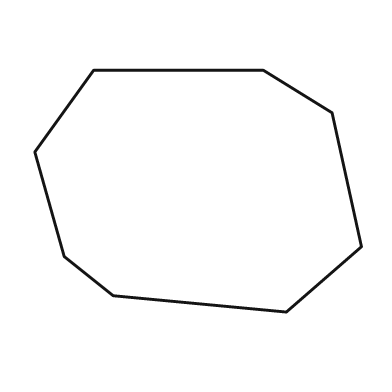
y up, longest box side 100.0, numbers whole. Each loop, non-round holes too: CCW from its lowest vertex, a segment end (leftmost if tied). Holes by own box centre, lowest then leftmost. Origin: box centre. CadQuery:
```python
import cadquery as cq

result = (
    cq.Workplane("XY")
    .moveTo(27.0, -37.0)
    .lineTo(50.0, -17.0)
    .lineTo(41.0, 24.0)
    .lineTo(20.0, 37.0)
    .lineTo(-32.0, 37.0)
    .lineTo(-50.0, 12.0)
    .lineTo(-41.0, -20.0)
    .lineTo(-26.0, -32.0)
    .close()
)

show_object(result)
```